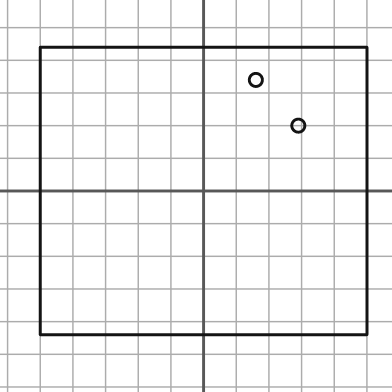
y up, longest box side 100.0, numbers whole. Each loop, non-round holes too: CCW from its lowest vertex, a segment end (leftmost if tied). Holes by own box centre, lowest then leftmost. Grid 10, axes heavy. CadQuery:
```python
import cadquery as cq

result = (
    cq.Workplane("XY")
    .moveTo(-50.0, -44.0)
    .lineTo(50.0, -44.0)
    .lineTo(50.0, 44.0)
    .lineTo(-50.0, 44.0)
    .close()
    .moveTo(29.0, 20.0)
    .circle(2.0)
    .moveTo(16.0, 34.0)
    .circle(2.0)
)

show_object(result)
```